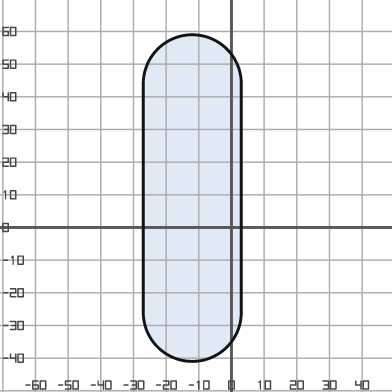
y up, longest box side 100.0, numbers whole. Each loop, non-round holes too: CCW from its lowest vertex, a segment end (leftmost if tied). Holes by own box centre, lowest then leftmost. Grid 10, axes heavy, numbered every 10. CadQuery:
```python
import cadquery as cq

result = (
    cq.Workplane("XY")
    .moveTo(-27.0, -26.0)
    .threePointArc((-12.0, -41.0), (3.0, -26.0))
    .lineTo(3.0, 44.0)
    .threePointArc((-12.0, 59.0), (-27.0, 44.0))
    .close()
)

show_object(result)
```